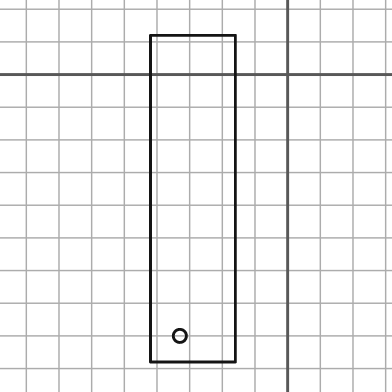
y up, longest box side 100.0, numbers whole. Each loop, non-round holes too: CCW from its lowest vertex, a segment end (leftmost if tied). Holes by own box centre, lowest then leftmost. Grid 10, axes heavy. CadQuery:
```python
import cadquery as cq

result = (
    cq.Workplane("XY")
    .moveTo(-42.0, -88.0)
    .lineTo(-16.0, -88.0)
    .lineTo(-16.0, 12.0)
    .lineTo(-42.0, 12.0)
    .close()
    .moveTo(-33.0, -80.0)
    .circle(2.0)
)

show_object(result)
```